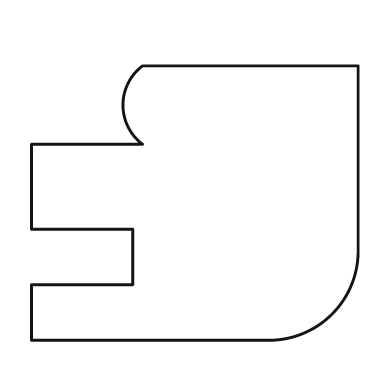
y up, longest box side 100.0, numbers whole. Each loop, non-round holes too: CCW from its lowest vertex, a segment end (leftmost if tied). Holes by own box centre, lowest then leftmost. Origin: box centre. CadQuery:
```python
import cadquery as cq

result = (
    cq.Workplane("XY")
    .moveTo(-50.0, -42.0)
    .lineTo(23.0, -42.0)
    .threePointArc((42.0, -34.0), (50.0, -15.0))
    .lineTo(50.0, 42.0)
    .lineTo(-16.0, 42.0)
    .threePointArc((-22.0, 30.0), (-16.0, 18.0))
    .lineTo(-50.0, 18.0)
    .lineTo(-50.0, -8.0)
    .lineTo(-19.0, -8.0)
    .lineTo(-19.0, -25.0)
    .lineTo(-50.0, -25.0)
    .close()
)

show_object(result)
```